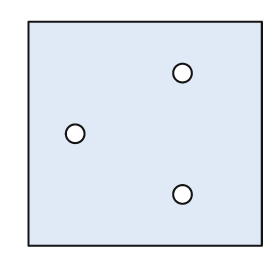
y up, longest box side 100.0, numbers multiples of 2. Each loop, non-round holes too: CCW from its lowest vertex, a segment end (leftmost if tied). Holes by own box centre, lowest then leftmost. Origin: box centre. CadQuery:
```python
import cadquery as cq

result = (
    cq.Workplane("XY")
    .moveTo(-50.0, -48.0)
    .lineTo(50.0, -48.0)
    .lineTo(50.0, 48.0)
    .lineTo(-50.0, 48.0)
    .close()
    .moveTo(16.0, -26.0)
    .circle(4.0)
    .moveTo(-30.0, 0.0)
    .circle(4.0)
    .moveTo(16.0, 26.0)
    .circle(4.0)
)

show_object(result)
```